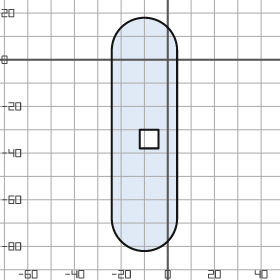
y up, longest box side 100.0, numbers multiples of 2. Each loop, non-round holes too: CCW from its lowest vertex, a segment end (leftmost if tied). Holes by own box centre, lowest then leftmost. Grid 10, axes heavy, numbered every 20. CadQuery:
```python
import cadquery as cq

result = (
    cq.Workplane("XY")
    .moveTo(-24.0, -68.0)
    .threePointArc((-10.0, -82.0), (4.0, -68.0))
    .lineTo(4.0, 4.0)
    .threePointArc((-10.0, 18.0), (-24.0, 4.0))
    .close()
    .moveTo(-12.0, -38.0)
    .lineTo(-4.0, -38.0)
    .lineTo(-4.0, -30.0)
    .lineTo(-12.0, -30.0)
    .close()
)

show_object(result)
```